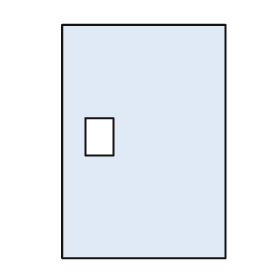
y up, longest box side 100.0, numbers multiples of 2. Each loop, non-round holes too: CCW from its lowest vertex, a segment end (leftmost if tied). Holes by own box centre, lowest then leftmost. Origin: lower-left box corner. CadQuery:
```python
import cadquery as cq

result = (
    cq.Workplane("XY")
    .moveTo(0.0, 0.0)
    .lineTo(70.0, 0.0)
    .lineTo(70.0, 100.0)
    .lineTo(0.0, 100.0)
    .close()
    .moveTo(10.0, 44.0)
    .lineTo(22.0, 44.0)
    .lineTo(22.0, 60.0)
    .lineTo(10.0, 60.0)
    .close()
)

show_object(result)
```